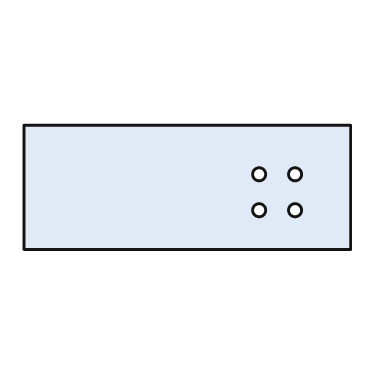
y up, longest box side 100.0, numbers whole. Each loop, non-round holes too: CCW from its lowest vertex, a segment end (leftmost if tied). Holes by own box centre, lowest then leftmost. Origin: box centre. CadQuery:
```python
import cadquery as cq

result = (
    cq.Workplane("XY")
    .moveTo(-50.0, -19.0)
    .lineTo(50.0, -19.0)
    .lineTo(50.0, 19.0)
    .lineTo(-50.0, 19.0)
    .close()
    .moveTo(22.0, -7.0)
    .circle(2.0)
    .moveTo(33.0, -7.0)
    .circle(2.0)
    .moveTo(22.0, 4.0)
    .circle(2.0)
    .moveTo(33.0, 4.0)
    .circle(2.0)
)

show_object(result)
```